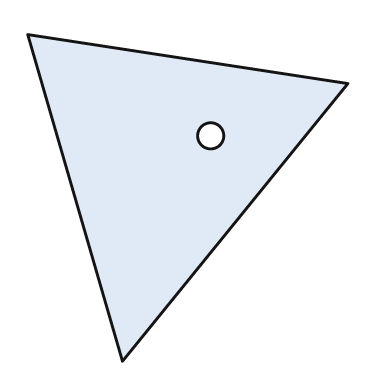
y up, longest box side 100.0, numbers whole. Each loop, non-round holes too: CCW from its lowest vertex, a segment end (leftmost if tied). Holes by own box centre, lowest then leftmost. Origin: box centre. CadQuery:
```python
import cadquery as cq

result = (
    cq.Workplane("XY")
    .moveTo(-20.0, -50.0)
    .lineTo(49.0, 35.0)
    .lineTo(-49.0, 50.0)
    .close()
    .moveTo(7.0, 19.0)
    .circle(4.0)
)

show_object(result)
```